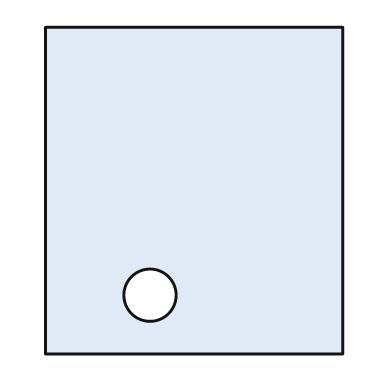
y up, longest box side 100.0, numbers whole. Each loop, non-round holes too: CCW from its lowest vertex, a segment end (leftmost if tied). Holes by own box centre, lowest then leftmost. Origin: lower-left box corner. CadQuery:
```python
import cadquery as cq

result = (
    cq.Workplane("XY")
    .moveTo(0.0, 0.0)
    .lineTo(91.0, 0.0)
    .lineTo(91.0, 100.0)
    .lineTo(0.0, 100.0)
    .close()
    .moveTo(32.0, 18.0)
    .circle(8.0)
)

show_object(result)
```